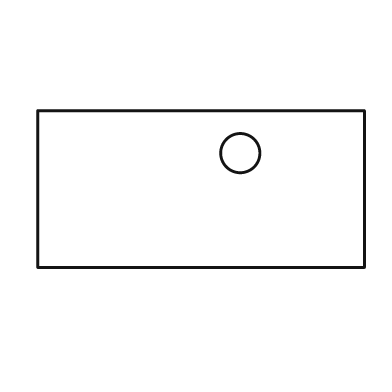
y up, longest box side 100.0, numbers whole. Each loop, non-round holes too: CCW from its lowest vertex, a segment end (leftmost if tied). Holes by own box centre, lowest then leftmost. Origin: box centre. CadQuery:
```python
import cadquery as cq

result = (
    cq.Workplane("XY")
    .moveTo(-50.0, -24.0)
    .lineTo(50.0, -24.0)
    .lineTo(50.0, 24.0)
    .lineTo(-50.0, 24.0)
    .close()
    .moveTo(12.0, 11.0)
    .circle(6.0)
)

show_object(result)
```